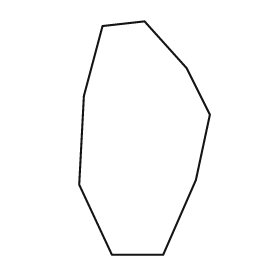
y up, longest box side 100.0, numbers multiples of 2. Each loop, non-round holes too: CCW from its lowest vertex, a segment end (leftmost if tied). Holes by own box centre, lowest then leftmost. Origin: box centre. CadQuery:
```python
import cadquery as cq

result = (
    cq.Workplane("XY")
    .moveTo(-14.0, -50.0)
    .lineTo(8.0, -50.0)
    .lineTo(22.0, -18.0)
    .lineTo(28.0, 10.0)
    .lineTo(18.0, 30.0)
    .lineTo(0.0, 50.0)
    .lineTo(-18.0, 48.0)
    .lineTo(-26.0, 18.0)
    .lineTo(-28.0, -20.0)
    .close()
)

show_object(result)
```